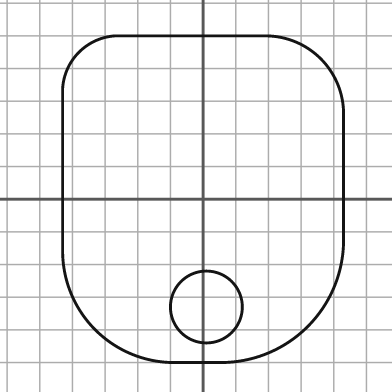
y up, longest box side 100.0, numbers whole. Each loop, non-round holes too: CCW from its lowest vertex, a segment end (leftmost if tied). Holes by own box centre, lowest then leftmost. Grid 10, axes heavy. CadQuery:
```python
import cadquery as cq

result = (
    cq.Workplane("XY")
    .moveTo(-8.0, -50.0)
    .lineTo(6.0, -50.0)
    .threePointArc((32.0, -39.0), (43.0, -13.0))
    .lineTo(43.0, 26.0)
    .threePointArc((36.0, 43.0), (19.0, 50.0))
    .lineTo(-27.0, 50.0)
    .threePointArc((-38.0, 45.0), (-43.0, 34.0))
    .lineTo(-43.0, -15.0)
    .threePointArc((-33.0, -40.0), (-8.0, -50.0))
    .close()
    .moveTo(1.0, -33.0)
    .circle(11.0)
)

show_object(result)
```